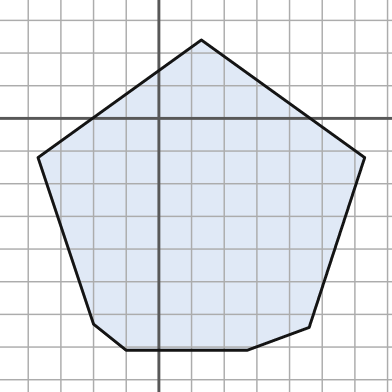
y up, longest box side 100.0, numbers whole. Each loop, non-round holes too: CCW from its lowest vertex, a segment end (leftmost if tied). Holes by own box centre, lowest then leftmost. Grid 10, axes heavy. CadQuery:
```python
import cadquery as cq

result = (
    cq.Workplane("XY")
    .moveTo(-10.0, -71.0)
    .lineTo(27.0, -71.0)
    .lineTo(46.0, -64.0)
    .lineTo(63.0, -12.0)
    .lineTo(13.0, 24.0)
    .lineTo(-37.0, -12.0)
    .lineTo(-20.0, -63.0)
    .close()
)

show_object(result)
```